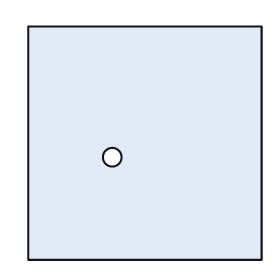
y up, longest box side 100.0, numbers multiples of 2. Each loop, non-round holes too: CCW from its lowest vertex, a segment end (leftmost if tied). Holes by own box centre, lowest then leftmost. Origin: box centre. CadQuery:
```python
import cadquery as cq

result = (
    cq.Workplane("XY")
    .moveTo(-50.0, -50.0)
    .lineTo(50.0, -50.0)
    .lineTo(50.0, 50.0)
    .lineTo(-50.0, 50.0)
    .close()
    .moveTo(-14.0, -6.0)
    .circle(4.0)
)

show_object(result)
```